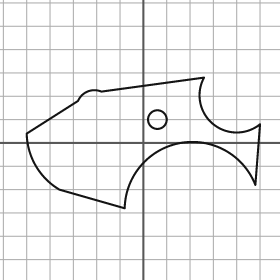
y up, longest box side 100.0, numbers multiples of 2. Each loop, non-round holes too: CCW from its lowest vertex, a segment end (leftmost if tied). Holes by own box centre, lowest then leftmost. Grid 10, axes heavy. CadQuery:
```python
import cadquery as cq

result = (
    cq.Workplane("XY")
    .moveTo(-8.0, -28.0)
    .threePointArc((16.0, 0.0), (48.0, -18.0))
    .lineTo(50.0, 8.0)
    .threePointArc((30.0, 8.0), (26.0, 28.0))
    .lineTo(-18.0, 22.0)
    .threePointArc((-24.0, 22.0), (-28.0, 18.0))
    .lineTo(-50.0, 4.0)
    .threePointArc((-46.0, -10.0), (-36.0, -20.0))
    .close()
    .moveTo(6.0, 10.0)
    .circle(4.0)
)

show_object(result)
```